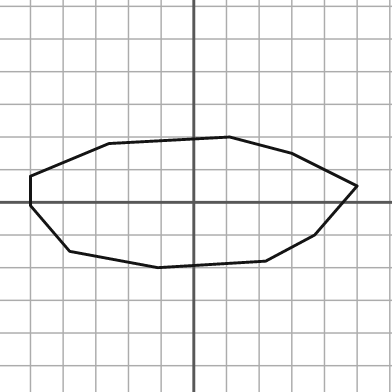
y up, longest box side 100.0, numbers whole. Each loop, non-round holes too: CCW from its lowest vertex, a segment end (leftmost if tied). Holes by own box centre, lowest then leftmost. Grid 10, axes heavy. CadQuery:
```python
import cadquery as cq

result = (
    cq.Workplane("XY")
    .moveTo(-11.0, -20.0)
    .lineTo(22.0, -18.0)
    .lineTo(37.0, -10.0)
    .lineTo(50.0, 5.0)
    .lineTo(30.0, 15.0)
    .lineTo(11.0, 20.0)
    .lineTo(-26.0, 18.0)
    .lineTo(-50.0, 8.0)
    .lineTo(-50.0, -1.0)
    .lineTo(-38.0, -15.0)
    .close()
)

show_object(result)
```